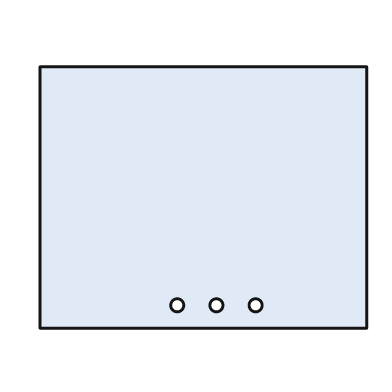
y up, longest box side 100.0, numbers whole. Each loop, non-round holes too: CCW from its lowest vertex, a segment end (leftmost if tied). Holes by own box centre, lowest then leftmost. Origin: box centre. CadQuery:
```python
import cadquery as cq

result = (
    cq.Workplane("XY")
    .moveTo(-50.0, -40.0)
    .lineTo(50.0, -40.0)
    .lineTo(50.0, 40.0)
    .lineTo(-50.0, 40.0)
    .close()
    .moveTo(-8.0, -33.0)
    .circle(2.0)
    .moveTo(4.0, -33.0)
    .circle(2.0)
    .moveTo(16.0, -33.0)
    .circle(2.0)
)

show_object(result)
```